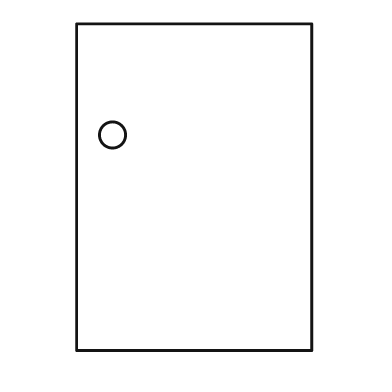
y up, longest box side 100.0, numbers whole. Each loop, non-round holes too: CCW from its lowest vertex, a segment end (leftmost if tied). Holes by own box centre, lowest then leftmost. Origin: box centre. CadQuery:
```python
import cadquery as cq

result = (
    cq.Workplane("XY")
    .moveTo(-36.0, -50.0)
    .lineTo(36.0, -50.0)
    .lineTo(36.0, 50.0)
    .lineTo(-36.0, 50.0)
    .close()
    .moveTo(-25.0, 16.0)
    .circle(4.0)
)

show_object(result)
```